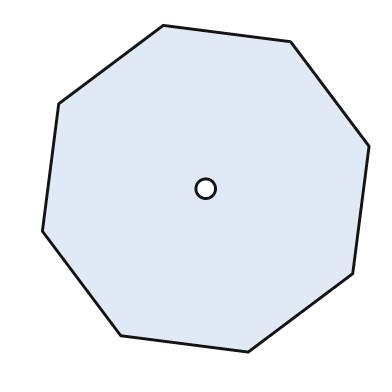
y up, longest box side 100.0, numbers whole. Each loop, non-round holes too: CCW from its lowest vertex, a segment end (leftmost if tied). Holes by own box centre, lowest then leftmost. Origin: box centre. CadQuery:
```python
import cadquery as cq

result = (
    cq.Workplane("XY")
    .moveTo(13.0, -50.0)
    .lineTo(45.0, -26.0)
    .lineTo(50.0, 13.0)
    .lineTo(26.0, 45.0)
    .lineTo(-13.0, 50.0)
    .lineTo(-45.0, 26.0)
    .lineTo(-50.0, -13.0)
    .lineTo(-26.0, -45.0)
    .close()
    .moveTo(0.0, 0.0)
    .circle(3.0)
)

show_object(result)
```